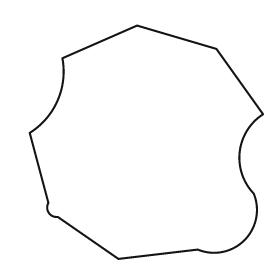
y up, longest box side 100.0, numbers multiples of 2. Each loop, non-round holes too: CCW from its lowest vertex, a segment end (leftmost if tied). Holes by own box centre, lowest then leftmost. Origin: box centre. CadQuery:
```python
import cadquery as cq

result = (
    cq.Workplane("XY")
    .moveTo(-12.0, -50.0)
    .lineTo(22.0, -46.0)
    .threePointArc((42.0, -42.0), (46.0, -22.0))
    .threePointArc((40.0, -4.0), (50.0, 12.0))
    .lineTo(30.0, 40.0)
    .lineTo(-4.0, 50.0)
    .lineTo(-36.0, 36.0)
    .threePointArc((-38.0, 18.0), (-50.0, 4.0))
    .lineTo(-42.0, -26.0)
    .threePointArc((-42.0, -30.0), (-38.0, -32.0))
    .close()
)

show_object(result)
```